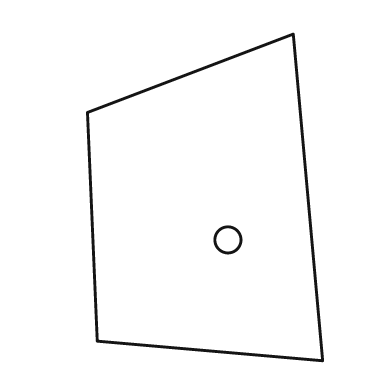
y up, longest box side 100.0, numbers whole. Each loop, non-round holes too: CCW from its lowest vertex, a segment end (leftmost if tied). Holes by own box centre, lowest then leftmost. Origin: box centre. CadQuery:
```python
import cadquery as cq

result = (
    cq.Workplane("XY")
    .moveTo(36.0, -50.0)
    .lineTo(27.0, 50.0)
    .lineTo(-36.0, 26.0)
    .lineTo(-33.0, -44.0)
    .close()
    .moveTo(7.0, -13.0)
    .circle(4.0)
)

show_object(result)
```